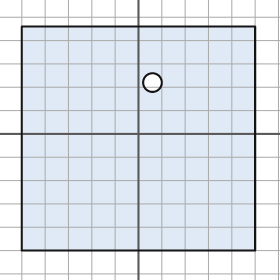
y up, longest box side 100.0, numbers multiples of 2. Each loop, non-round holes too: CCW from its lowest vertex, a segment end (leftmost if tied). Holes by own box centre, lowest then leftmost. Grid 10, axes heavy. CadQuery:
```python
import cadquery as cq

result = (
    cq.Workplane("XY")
    .moveTo(-50.0, -50.0)
    .lineTo(50.0, -50.0)
    .lineTo(50.0, 46.0)
    .lineTo(-50.0, 46.0)
    .close()
    .moveTo(6.0, 22.0)
    .circle(4.0)
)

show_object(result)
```